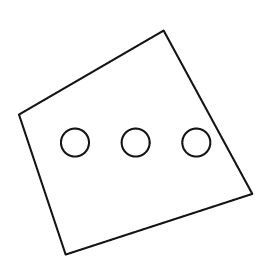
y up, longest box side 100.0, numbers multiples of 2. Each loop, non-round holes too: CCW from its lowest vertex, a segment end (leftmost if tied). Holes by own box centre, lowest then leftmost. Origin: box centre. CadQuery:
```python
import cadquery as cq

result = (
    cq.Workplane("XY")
    .moveTo(-30.0, -48.0)
    .lineTo(50.0, -22.0)
    .lineTo(12.0, 48.0)
    .lineTo(-50.0, 12.0)
    .close()
    .moveTo(-26.0, 0.0)
    .circle(6.0)
    .moveTo(0.0, 0.0)
    .circle(6.0)
    .moveTo(26.0, 0.0)
    .circle(6.0)
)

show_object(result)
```